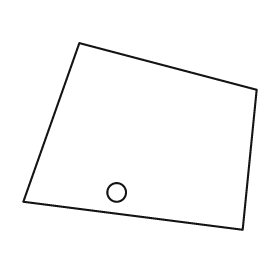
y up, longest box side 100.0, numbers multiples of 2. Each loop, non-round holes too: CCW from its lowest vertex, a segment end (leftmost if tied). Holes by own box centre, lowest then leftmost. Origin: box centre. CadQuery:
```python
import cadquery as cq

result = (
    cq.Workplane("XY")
    .moveTo(44.0, -40.0)
    .lineTo(50.0, 20.0)
    .lineTo(-26.0, 40.0)
    .lineTo(-50.0, -28.0)
    .close()
    .moveTo(-10.0, -24.0)
    .circle(4.0)
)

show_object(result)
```